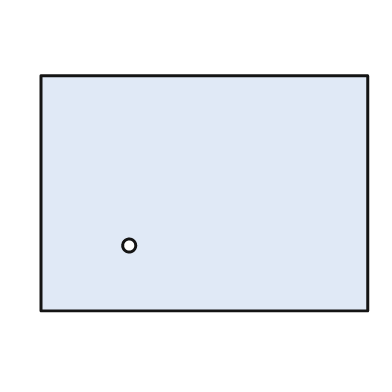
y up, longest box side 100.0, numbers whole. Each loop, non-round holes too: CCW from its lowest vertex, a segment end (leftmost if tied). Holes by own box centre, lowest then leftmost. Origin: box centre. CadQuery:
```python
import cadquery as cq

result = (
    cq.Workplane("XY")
    .moveTo(-50.0, -36.0)
    .lineTo(50.0, -36.0)
    .lineTo(50.0, 36.0)
    .lineTo(-50.0, 36.0)
    .close()
    .moveTo(-23.0, -16.0)
    .circle(2.0)
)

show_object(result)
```